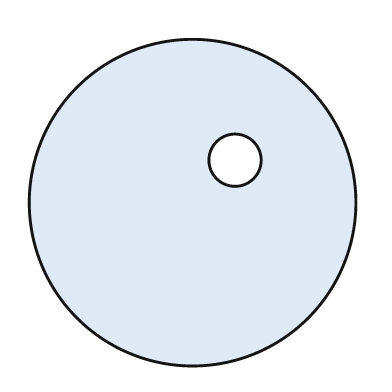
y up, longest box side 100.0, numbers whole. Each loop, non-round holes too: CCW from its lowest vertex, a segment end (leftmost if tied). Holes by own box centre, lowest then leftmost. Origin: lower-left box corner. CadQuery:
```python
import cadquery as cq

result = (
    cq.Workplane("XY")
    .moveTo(50.0, 50.0)
    .circle(50.0)
    .moveTo(63.0, 63.0)
    .circle(8.0)
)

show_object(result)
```